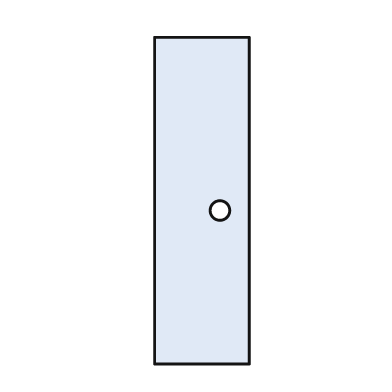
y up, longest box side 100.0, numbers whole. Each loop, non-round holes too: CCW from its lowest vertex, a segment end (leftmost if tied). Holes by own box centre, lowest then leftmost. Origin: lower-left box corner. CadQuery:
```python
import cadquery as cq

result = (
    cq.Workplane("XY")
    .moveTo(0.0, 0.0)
    .lineTo(29.0, 0.0)
    .lineTo(29.0, 100.0)
    .lineTo(0.0, 100.0)
    .close()
    .moveTo(20.0, 47.0)
    .circle(3.0)
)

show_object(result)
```